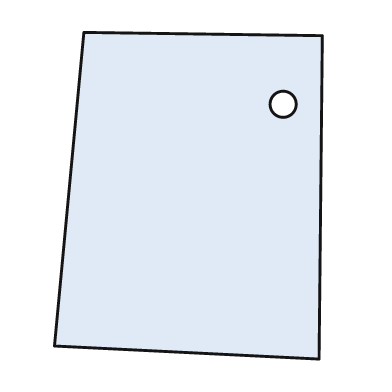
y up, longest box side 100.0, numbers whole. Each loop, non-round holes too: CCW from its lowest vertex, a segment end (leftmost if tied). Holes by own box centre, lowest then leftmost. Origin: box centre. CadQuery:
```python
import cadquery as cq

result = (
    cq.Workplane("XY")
    .moveTo(40.0, -50.0)
    .lineTo(41.0, 49.0)
    .lineTo(-32.0, 50.0)
    .lineTo(-41.0, -46.0)
    .close()
    .moveTo(29.0, 28.0)
    .circle(4.0)
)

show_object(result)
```